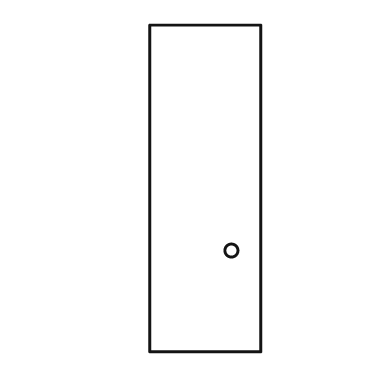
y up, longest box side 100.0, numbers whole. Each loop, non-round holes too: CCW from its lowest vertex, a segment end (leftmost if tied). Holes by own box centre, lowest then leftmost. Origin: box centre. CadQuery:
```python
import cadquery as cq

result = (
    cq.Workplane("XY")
    .moveTo(-17.0, -50.0)
    .lineTo(17.0, -50.0)
    .lineTo(17.0, 50.0)
    .lineTo(-17.0, 50.0)
    .close()
    .moveTo(8.0, -19.0)
    .circle(2.0)
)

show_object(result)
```